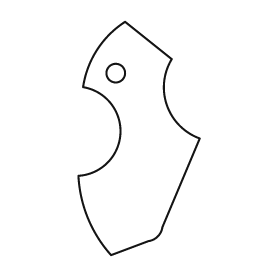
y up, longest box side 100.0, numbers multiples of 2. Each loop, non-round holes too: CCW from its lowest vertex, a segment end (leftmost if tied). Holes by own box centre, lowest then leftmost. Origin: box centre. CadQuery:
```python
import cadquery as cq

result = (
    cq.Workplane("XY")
    .moveTo(-12.0, -50.0)
    .lineTo(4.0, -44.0)
    .threePointArc((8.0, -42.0), (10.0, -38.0))
    .lineTo(26.0, 0.0)
    .threePointArc((12.0, 14.0), (14.0, 34.0))
    .lineTo(-6.0, 50.0)
    .threePointArc((-18.0, 38.0), (-24.0, 22.0))
    .threePointArc((-8.0, 2.0), (-26.0, -16.0))
    .threePointArc((-22.0, -34.0), (-12.0, -50.0))
    .close()
    .moveTo(-10.0, 28.0)
    .circle(4.0)
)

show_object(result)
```